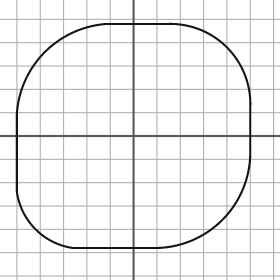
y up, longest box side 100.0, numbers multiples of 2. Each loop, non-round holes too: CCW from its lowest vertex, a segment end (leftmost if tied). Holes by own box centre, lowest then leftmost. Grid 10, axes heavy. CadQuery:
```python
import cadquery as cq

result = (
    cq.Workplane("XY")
    .moveTo(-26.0, -48.0)
    .lineTo(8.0, -48.0)
    .threePointArc((38.0, -36.0), (50.0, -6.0))
    .lineTo(50.0, 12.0)
    .threePointArc((40.0, 38.0), (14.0, 48.0))
    .lineTo(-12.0, 48.0)
    .threePointArc((-38.0, 36.0), (-50.0, 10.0))
    .lineTo(-50.0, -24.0)
    .threePointArc((-42.0, -40.0), (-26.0, -48.0))
    .close()
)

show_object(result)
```